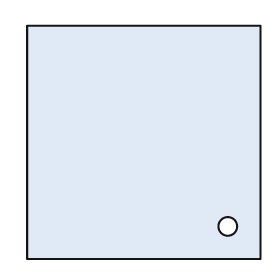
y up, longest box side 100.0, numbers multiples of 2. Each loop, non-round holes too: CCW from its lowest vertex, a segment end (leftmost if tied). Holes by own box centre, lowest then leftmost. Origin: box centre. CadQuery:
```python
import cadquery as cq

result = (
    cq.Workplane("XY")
    .moveTo(-50.0, -50.0)
    .lineTo(50.0, -50.0)
    .lineTo(50.0, 50.0)
    .lineTo(-50.0, 50.0)
    .close()
    .moveTo(36.0, -36.0)
    .circle(4.0)
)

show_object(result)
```